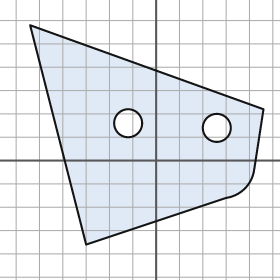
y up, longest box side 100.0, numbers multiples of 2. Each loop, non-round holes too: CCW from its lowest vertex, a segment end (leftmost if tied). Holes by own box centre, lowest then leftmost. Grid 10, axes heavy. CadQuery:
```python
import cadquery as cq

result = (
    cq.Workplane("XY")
    .moveTo(-30.0, -36.0)
    .lineTo(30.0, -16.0)
    .threePointArc((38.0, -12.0), (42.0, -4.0))
    .lineTo(46.0, 22.0)
    .lineTo(-54.0, 58.0)
    .close()
    .moveTo(26.0, 14.0)
    .circle(6.0)
    .moveTo(-12.0, 16.0)
    .circle(6.0)
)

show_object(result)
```